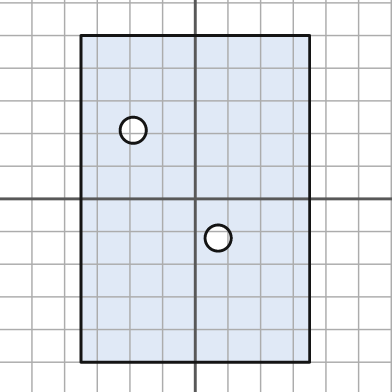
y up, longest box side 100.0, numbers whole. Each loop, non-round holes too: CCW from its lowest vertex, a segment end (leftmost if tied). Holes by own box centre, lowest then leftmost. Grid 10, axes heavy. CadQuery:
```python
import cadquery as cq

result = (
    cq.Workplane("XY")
    .moveTo(-35.0, -50.0)
    .lineTo(35.0, -50.0)
    .lineTo(35.0, 50.0)
    .lineTo(-35.0, 50.0)
    .close()
    .moveTo(7.0, -12.0)
    .circle(4.0)
    .moveTo(-19.0, 21.0)
    .circle(4.0)
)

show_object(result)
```